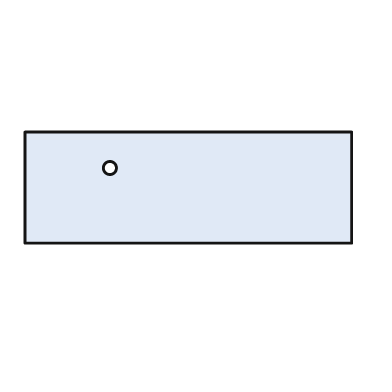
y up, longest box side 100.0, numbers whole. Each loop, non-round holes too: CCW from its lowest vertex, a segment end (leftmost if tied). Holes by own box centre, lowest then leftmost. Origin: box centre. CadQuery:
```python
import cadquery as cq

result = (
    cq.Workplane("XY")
    .moveTo(-50.0, -17.0)
    .lineTo(50.0, -17.0)
    .lineTo(50.0, 17.0)
    .lineTo(-50.0, 17.0)
    .close()
    .moveTo(-24.0, 6.0)
    .circle(2.0)
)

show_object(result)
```